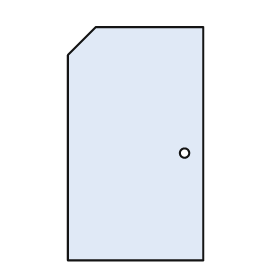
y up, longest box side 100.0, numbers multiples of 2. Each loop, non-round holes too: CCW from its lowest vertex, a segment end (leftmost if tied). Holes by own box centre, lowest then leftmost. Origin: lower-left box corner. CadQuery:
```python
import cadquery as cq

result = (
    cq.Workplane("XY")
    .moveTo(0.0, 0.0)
    .lineTo(58.0, 0.0)
    .lineTo(58.0, 100.0)
    .lineTo(12.0, 100.0)
    .lineTo(0.0, 88.0)
    .close()
    .moveTo(50.0, 46.0)
    .circle(2.0)
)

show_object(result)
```